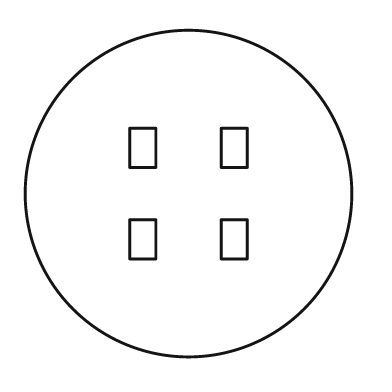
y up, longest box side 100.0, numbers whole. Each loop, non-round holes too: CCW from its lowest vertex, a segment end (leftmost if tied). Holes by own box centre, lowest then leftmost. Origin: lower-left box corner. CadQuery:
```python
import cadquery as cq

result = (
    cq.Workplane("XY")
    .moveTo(50.0, 50.0)
    .circle(50.0)
    .moveTo(32.0, 30.0)
    .lineTo(40.0, 30.0)
    .lineTo(40.0, 42.0)
    .lineTo(32.0, 42.0)
    .close()
    .moveTo(60.0, 30.0)
    .lineTo(68.0, 30.0)
    .lineTo(68.0, 42.0)
    .lineTo(60.0, 42.0)
    .close()
    .moveTo(32.0, 58.0)
    .lineTo(40.0, 58.0)
    .lineTo(40.0, 70.0)
    .lineTo(32.0, 70.0)
    .close()
    .moveTo(60.0, 58.0)
    .lineTo(68.0, 58.0)
    .lineTo(68.0, 70.0)
    .lineTo(60.0, 70.0)
    .close()
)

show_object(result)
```